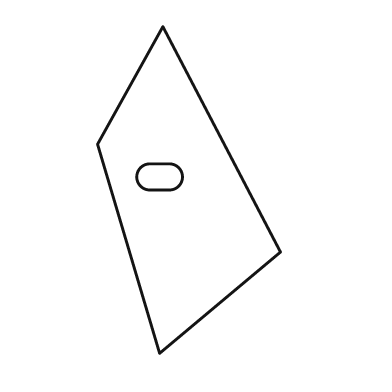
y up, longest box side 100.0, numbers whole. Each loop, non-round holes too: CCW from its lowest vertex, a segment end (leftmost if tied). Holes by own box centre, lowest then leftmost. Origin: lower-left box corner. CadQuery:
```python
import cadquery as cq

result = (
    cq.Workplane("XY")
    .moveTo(19.0, 0.0)
    .lineTo(56.0, 31.0)
    .lineTo(20.0, 100.0)
    .lineTo(0.0, 64.0)
    .close()
    .moveTo(16.0, 50.0)
    .lineTo(22.0, 50.0)
    .threePointArc((26.0, 54.0), (22.0, 58.0))
    .lineTo(16.0, 58.0)
    .threePointArc((12.0, 54.0), (16.0, 50.0))
    .close()
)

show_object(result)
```